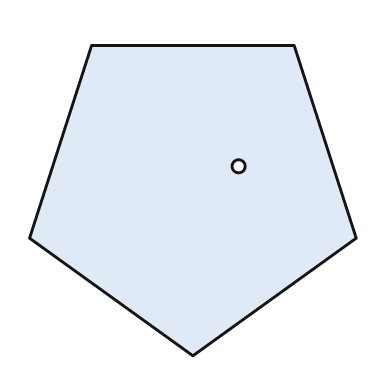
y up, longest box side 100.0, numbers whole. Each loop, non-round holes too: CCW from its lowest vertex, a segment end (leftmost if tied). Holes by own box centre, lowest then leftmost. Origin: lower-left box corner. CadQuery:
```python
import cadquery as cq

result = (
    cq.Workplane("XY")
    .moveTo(50.0, 0.0)
    .lineTo(100.0, 36.0)
    .lineTo(81.0, 95.0)
    .lineTo(19.0, 95.0)
    .lineTo(0.0, 36.0)
    .close()
    .moveTo(64.0, 58.0)
    .circle(2.0)
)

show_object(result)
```